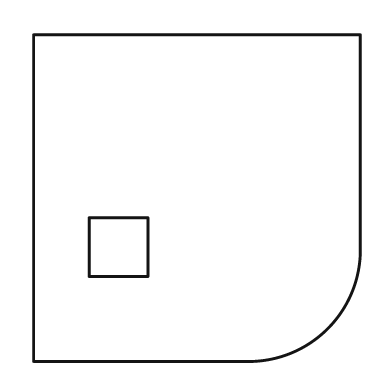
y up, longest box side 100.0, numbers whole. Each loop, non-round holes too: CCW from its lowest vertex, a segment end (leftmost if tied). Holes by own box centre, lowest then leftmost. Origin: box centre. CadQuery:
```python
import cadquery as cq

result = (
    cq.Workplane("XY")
    .moveTo(-50.0, -50.0)
    .lineTo(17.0, -50.0)
    .threePointArc((40.0, -40.0), (50.0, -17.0))
    .lineTo(50.0, 50.0)
    .lineTo(-50.0, 50.0)
    .close()
    .moveTo(-33.0, -24.0)
    .lineTo(-15.0, -24.0)
    .lineTo(-15.0, -6.0)
    .lineTo(-33.0, -6.0)
    .close()
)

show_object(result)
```